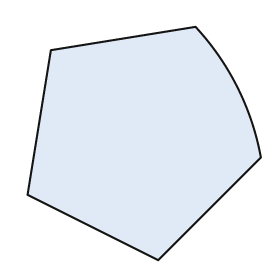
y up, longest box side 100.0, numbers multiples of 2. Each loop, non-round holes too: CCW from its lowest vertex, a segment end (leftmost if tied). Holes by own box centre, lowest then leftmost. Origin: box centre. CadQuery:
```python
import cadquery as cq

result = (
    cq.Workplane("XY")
    .moveTo(6.0, -50.0)
    .lineTo(50.0, -6.0)
    .threePointArc((40.0, 24.0), (22.0, 50.0))
    .lineTo(-40.0, 40.0)
    .lineTo(-50.0, -22.0)
    .close()
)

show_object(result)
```